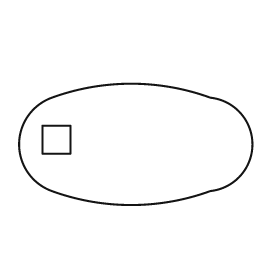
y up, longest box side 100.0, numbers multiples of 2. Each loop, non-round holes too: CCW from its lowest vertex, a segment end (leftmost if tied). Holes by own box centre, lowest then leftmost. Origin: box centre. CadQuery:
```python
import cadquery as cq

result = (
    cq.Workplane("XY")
    .moveTo(-36.0, -20.0)
    .threePointArc((-2.0, -26.0), (32.0, -20.0))
    .threePointArc((50.0, 0.0), (32.0, 20.0))
    .threePointArc((-2.0, 26.0), (-36.0, 20.0))
    .threePointArc((-50.0, 0.0), (-36.0, -20.0))
    .close()
    .moveTo(-40.0, -4.0)
    .lineTo(-28.0, -4.0)
    .lineTo(-28.0, 8.0)
    .lineTo(-40.0, 8.0)
    .close()
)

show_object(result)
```